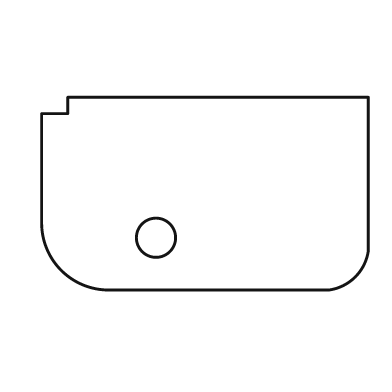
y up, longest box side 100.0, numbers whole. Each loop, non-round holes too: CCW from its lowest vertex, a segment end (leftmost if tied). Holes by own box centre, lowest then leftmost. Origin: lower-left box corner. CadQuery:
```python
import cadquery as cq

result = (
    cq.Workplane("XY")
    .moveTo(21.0, 0.0)
    .lineTo(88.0, 0.0)
    .threePointArc((96.0, 4.0), (100.0, 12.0))
    .lineTo(100.0, 59.0)
    .lineTo(8.0, 59.0)
    .lineTo(8.0, 54.0)
    .lineTo(0.0, 54.0)
    .lineTo(0.0, 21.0)
    .threePointArc((6.0, 6.0), (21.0, 0.0))
    .close()
    .moveTo(35.0, 16.0)
    .circle(6.0)
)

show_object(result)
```